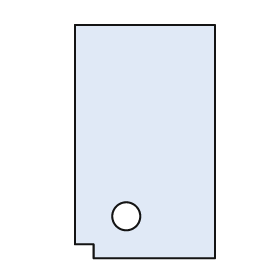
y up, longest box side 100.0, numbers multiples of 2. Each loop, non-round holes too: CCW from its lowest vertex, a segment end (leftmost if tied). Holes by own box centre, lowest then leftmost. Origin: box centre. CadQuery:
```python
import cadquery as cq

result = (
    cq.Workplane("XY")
    .moveTo(-22.0, -50.0)
    .lineTo(30.0, -50.0)
    .lineTo(30.0, 50.0)
    .lineTo(-30.0, 50.0)
    .lineTo(-30.0, -44.0)
    .lineTo(-22.0, -44.0)
    .close()
    .moveTo(-8.0, -32.0)
    .circle(6.0)
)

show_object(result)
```